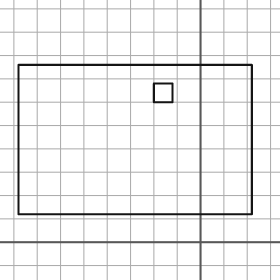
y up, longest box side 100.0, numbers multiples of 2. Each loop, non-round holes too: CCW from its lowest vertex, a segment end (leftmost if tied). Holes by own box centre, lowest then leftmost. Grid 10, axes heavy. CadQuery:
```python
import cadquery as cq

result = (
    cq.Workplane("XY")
    .moveTo(-78.0, 12.0)
    .lineTo(22.0, 12.0)
    .lineTo(22.0, 76.0)
    .lineTo(-78.0, 76.0)
    .close()
    .moveTo(-20.0, 60.0)
    .lineTo(-12.0, 60.0)
    .lineTo(-12.0, 68.0)
    .lineTo(-20.0, 68.0)
    .close()
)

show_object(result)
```